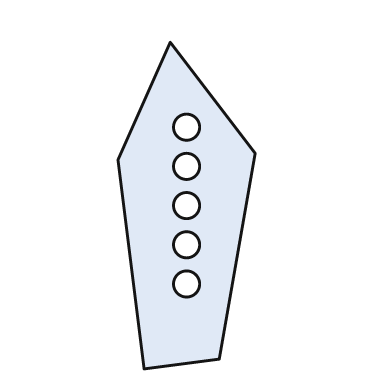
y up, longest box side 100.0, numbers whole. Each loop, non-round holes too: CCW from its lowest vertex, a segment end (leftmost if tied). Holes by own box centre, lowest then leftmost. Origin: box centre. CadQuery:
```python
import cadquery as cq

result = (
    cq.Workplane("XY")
    .moveTo(-13.0, -50.0)
    .lineTo(10.0, -47.0)
    .lineTo(21.0, 16.0)
    .lineTo(-5.0, 50.0)
    .lineTo(-21.0, 14.0)
    .close()
    .moveTo(0.0, -24.0)
    .circle(4.0)
    .moveTo(0.0, -12.0)
    .circle(4.0)
    .moveTo(0.0, 0.0)
    .circle(4.0)
    .moveTo(0.0, 12.0)
    .circle(4.0)
    .moveTo(0.0, 24.0)
    .circle(4.0)
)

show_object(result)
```